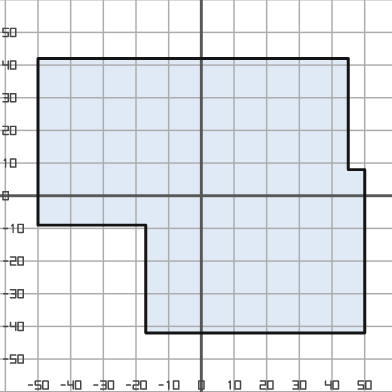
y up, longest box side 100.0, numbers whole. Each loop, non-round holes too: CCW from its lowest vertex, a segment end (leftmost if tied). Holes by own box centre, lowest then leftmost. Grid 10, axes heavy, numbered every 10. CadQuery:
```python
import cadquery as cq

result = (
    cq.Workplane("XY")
    .moveTo(-17.0, -42.0)
    .lineTo(50.0, -42.0)
    .lineTo(50.0, 8.0)
    .lineTo(45.0, 8.0)
    .lineTo(45.0, 42.0)
    .lineTo(-50.0, 42.0)
    .lineTo(-50.0, -9.0)
    .lineTo(-17.0, -9.0)
    .close()
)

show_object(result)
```